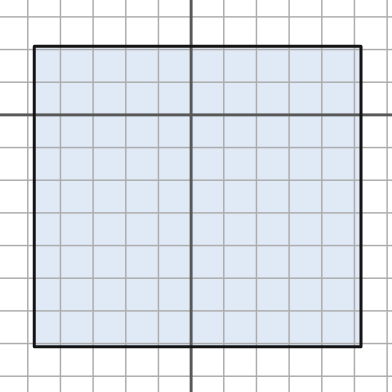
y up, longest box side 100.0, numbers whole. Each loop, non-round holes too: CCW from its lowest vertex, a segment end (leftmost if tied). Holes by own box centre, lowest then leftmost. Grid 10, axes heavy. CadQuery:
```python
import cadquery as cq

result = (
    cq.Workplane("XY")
    .moveTo(-48.0, -71.0)
    .lineTo(52.0, -71.0)
    .lineTo(52.0, 21.0)
    .lineTo(-48.0, 21.0)
    .close()
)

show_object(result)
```